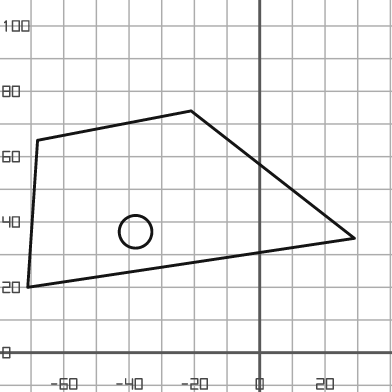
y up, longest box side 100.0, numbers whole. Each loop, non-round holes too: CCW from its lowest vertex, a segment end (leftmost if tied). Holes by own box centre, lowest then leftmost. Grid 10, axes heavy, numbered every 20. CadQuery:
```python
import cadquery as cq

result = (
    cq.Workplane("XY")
    .moveTo(-71.0, 20.0)
    .lineTo(29.0, 35.0)
    .lineTo(-21.0, 74.0)
    .lineTo(-68.0, 65.0)
    .close()
    .moveTo(-38.0, 37.0)
    .circle(5.0)
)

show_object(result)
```